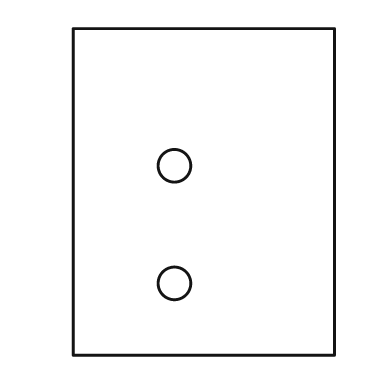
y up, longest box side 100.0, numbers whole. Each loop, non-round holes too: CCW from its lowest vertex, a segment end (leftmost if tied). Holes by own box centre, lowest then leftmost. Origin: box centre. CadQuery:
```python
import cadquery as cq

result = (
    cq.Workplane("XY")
    .moveTo(-40.0, -50.0)
    .lineTo(40.0, -50.0)
    .lineTo(40.0, 50.0)
    .lineTo(-40.0, 50.0)
    .close()
    .moveTo(-9.0, -28.0)
    .circle(5.0)
    .moveTo(-9.0, 8.0)
    .circle(5.0)
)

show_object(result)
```